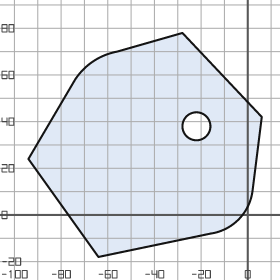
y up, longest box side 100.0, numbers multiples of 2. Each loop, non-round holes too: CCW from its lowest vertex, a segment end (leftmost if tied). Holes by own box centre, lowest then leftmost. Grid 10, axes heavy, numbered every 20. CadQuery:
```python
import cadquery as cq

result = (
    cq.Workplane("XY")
    .moveTo(-64.0, -18.0)
    .lineTo(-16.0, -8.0)
    .threePointArc((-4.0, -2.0), (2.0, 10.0))
    .lineTo(6.0, 42.0)
    .lineTo(-28.0, 78.0)
    .lineTo(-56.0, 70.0)
    .threePointArc((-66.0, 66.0), (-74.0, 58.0))
    .lineTo(-94.0, 24.0)
    .close()
    .moveTo(-22.0, 38.0)
    .circle(6.0)
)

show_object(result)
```